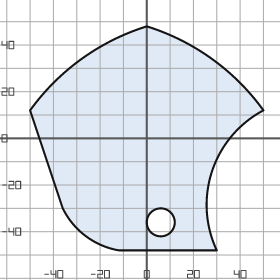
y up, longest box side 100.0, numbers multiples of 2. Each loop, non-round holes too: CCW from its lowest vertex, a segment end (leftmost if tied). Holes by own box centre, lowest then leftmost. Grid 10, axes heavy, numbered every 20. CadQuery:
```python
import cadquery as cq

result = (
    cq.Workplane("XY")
    .moveTo(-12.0, -48.0)
    .lineTo(30.0, -48.0)
    .threePointArc((28.0, -14.0), (50.0, 12.0))
    .threePointArc((28.0, 34.0), (0.0, 48.0))
    .threePointArc((-28.0, 34.0), (-50.0, 12.0))
    .lineTo(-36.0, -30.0)
    .threePointArc((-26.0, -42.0), (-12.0, -48.0))
    .close()
    .moveTo(6.0, -36.0)
    .circle(6.0)
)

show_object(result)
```